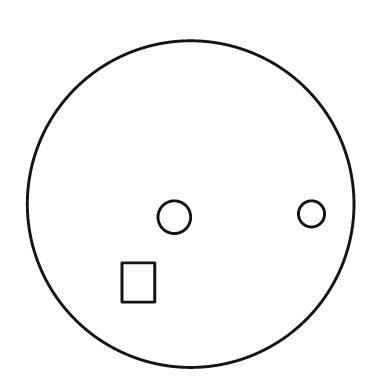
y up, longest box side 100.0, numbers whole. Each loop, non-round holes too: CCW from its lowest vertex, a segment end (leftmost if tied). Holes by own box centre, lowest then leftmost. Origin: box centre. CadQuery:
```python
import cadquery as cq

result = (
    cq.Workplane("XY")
    .moveTo(0.0, 0.0)
    .circle(50.0)
    .moveTo(-21.0, -30.0)
    .lineTo(-11.0, -30.0)
    .lineTo(-11.0, -18.0)
    .lineTo(-21.0, -18.0)
    .close()
    .moveTo(-5.0, -4.0)
    .circle(5.0)
    .moveTo(37.0, -3.0)
    .circle(4.0)
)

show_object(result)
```